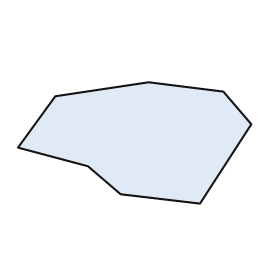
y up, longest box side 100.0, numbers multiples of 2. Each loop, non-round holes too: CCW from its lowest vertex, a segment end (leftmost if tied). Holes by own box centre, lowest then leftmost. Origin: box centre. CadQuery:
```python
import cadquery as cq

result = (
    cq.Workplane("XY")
    .moveTo(28.0, -26.0)
    .lineTo(50.0, 8.0)
    .lineTo(38.0, 22.0)
    .lineTo(6.0, 26.0)
    .lineTo(-34.0, 20.0)
    .lineTo(-50.0, -2.0)
    .lineTo(-20.0, -10.0)
    .lineTo(-6.0, -22.0)
    .close()
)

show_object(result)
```